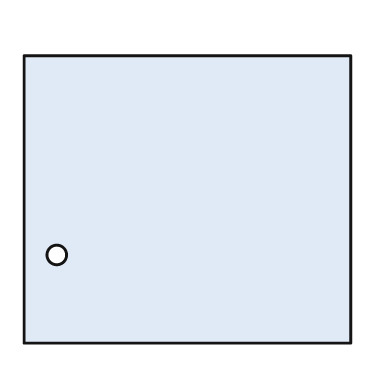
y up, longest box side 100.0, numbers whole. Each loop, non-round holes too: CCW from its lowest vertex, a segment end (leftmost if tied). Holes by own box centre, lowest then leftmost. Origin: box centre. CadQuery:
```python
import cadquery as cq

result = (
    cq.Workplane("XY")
    .moveTo(-50.0, -44.0)
    .lineTo(50.0, -44.0)
    .lineTo(50.0, 44.0)
    .lineTo(-50.0, 44.0)
    .close()
    .moveTo(-40.0, -17.0)
    .circle(3.0)
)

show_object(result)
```